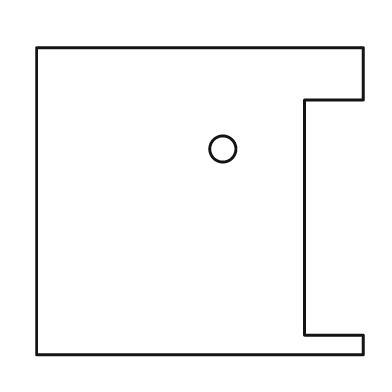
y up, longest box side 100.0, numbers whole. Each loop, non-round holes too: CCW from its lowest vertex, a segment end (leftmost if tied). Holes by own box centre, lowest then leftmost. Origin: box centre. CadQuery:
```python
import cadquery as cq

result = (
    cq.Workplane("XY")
    .moveTo(-50.0, -47.0)
    .lineTo(50.0, -47.0)
    .lineTo(50.0, -41.0)
    .lineTo(32.0, -41.0)
    .lineTo(32.0, 31.0)
    .lineTo(50.0, 31.0)
    .lineTo(50.0, 47.0)
    .lineTo(-50.0, 47.0)
    .close()
    .moveTo(7.0, 16.0)
    .circle(4.0)
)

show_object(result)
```